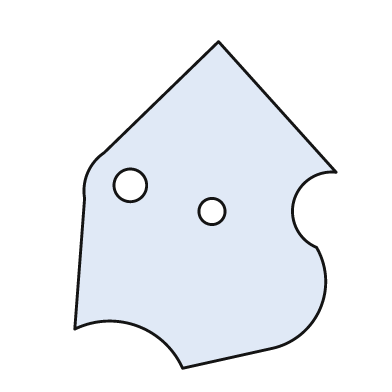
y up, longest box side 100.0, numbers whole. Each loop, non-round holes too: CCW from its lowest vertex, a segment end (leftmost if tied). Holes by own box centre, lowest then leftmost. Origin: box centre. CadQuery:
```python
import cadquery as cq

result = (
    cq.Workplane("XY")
    .moveTo(-7.0, -50.0)
    .lineTo(20.0, -44.0)
    .threePointArc((35.0, -32.0), (34.0, -13.0))
    .threePointArc((27.0, 1.0), (40.0, 10.0))
    .lineTo(4.0, 50.0)
    .lineTo(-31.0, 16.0)
    .threePointArc((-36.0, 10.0), (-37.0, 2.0))
    .lineTo(-40.0, -38.0)
    .threePointArc((-21.0, -37.0), (-7.0, -50.0))
    .close()
    .moveTo(2.0, -2.0)
    .circle(4.0)
    .moveTo(-23.0, 6.0)
    .circle(5.0)
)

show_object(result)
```